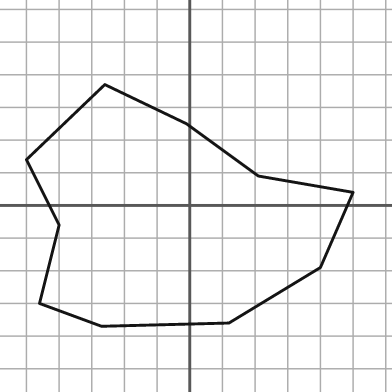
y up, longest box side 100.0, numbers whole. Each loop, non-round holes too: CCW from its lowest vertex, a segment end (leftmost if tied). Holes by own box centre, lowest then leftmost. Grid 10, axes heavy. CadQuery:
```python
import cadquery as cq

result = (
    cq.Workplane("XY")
    .moveTo(-27.0, -37.0)
    .lineTo(12.0, -36.0)
    .lineTo(40.0, -19.0)
    .lineTo(50.0, 4.0)
    .lineTo(21.0, 9.0)
    .lineTo(-1.0, 25.0)
    .lineTo(-26.0, 37.0)
    .lineTo(-50.0, 14.0)
    .lineTo(-40.0, -6.0)
    .lineTo(-46.0, -30.0)
    .close()
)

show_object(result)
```